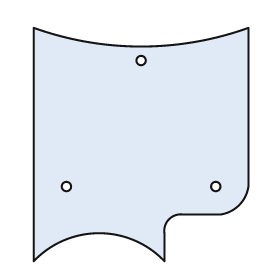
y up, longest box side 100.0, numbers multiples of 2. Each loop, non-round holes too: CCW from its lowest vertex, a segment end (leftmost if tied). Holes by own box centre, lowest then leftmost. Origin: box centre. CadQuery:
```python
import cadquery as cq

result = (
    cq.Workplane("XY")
    .moveTo(-46.0, -50.0)
    .threePointArc((-18.0, -38.0), (10.0, -50.0))
    .lineTo(10.0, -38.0)
    .threePointArc((12.0, -32.0), (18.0, -30.0))
    .lineTo(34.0, -30.0)
    .threePointArc((42.0, -26.0), (46.0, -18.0))
    .lineTo(46.0, 50.0)
    .threePointArc((0.0, 42.0), (-46.0, 50.0))
    .close()
    .moveTo(-32.0, -18.0)
    .circle(2.0)
    .moveTo(32.0, -18.0)
    .circle(2.0)
    .moveTo(0.0, 36.0)
    .circle(2.0)
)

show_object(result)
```